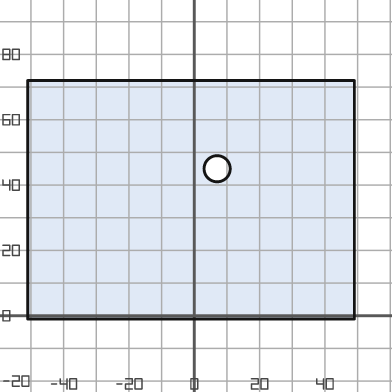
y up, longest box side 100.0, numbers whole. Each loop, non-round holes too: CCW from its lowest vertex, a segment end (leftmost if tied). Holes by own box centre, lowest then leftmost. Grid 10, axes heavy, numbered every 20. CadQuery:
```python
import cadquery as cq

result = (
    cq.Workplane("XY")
    .moveTo(-51.0, -1.0)
    .lineTo(49.0, -1.0)
    .lineTo(49.0, 72.0)
    .lineTo(-51.0, 72.0)
    .close()
    .moveTo(7.0, 45.0)
    .circle(4.0)
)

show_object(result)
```